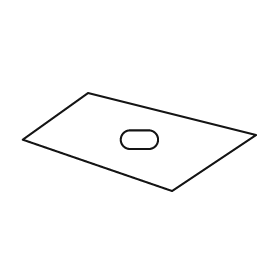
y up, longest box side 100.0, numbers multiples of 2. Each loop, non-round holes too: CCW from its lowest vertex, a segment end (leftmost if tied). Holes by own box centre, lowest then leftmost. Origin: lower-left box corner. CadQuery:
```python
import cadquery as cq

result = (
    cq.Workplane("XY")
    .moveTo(64.0, 0.0)
    .lineTo(100.0, 24.0)
    .lineTo(28.0, 42.0)
    .lineTo(0.0, 22.0)
    .close()
    .moveTo(46.0, 18.0)
    .lineTo(54.0, 18.0)
    .threePointArc((58.0, 22.0), (54.0, 26.0))
    .lineTo(46.0, 26.0)
    .threePointArc((42.0, 22.0), (46.0, 18.0))
    .close()
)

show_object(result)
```